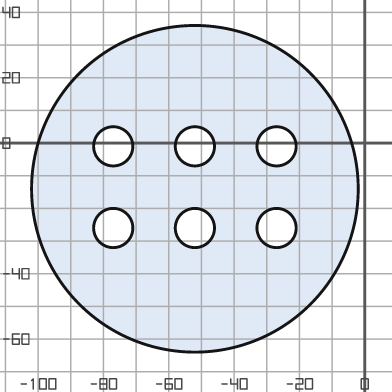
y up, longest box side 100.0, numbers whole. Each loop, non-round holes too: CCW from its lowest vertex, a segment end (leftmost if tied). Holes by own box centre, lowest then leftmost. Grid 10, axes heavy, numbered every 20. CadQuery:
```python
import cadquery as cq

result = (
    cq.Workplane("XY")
    .moveTo(-52.0, -14.0)
    .circle(50.0)
    .moveTo(-77.0, -26.0)
    .circle(6.0)
    .moveTo(-52.0, -26.0)
    .circle(6.0)
    .moveTo(-27.0, -26.0)
    .circle(6.0)
    .moveTo(-77.0, -1.0)
    .circle(6.0)
    .moveTo(-52.0, -1.0)
    .circle(6.0)
    .moveTo(-27.0, -1.0)
    .circle(6.0)
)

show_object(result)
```